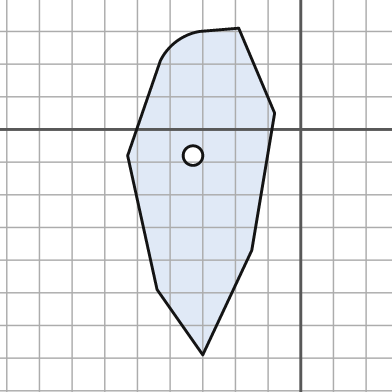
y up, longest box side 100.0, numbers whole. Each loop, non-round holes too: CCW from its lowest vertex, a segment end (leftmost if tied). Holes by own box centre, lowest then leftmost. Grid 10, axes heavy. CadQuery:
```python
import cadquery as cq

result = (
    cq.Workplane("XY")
    .moveTo(-30.0, -69.0)
    .lineTo(-15.0, -37.0)
    .lineTo(-8.0, 5.0)
    .lineTo(-19.0, 31.0)
    .lineTo(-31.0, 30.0)
    .threePointArc((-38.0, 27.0), (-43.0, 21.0))
    .lineTo(-53.0, -8.0)
    .lineTo(-44.0, -49.0)
    .close()
    .moveTo(-33.0, -8.0)
    .circle(3.0)
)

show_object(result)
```